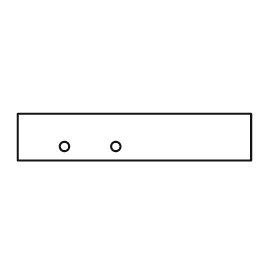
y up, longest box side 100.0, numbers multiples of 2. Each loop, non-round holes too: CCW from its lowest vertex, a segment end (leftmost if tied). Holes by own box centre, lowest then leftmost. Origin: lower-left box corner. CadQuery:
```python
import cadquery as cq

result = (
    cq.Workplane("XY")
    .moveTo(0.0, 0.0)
    .lineTo(100.0, 0.0)
    .lineTo(100.0, 20.0)
    .lineTo(0.0, 20.0)
    .close()
    .moveTo(20.0, 6.0)
    .circle(2.0)
    .moveTo(42.0, 6.0)
    .circle(2.0)
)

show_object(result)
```